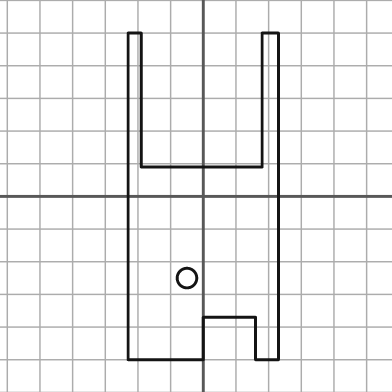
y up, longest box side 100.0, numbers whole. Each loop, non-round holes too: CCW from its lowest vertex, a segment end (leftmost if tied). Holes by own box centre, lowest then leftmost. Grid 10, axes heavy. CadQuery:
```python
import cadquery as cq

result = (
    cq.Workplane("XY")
    .moveTo(-23.0, -50.0)
    .lineTo(0.0, -50.0)
    .lineTo(0.0, -37.0)
    .lineTo(16.0, -37.0)
    .lineTo(16.0, -50.0)
    .lineTo(23.0, -50.0)
    .lineTo(23.0, 50.0)
    .lineTo(18.0, 50.0)
    .lineTo(18.0, 9.0)
    .lineTo(-19.0, 9.0)
    .lineTo(-19.0, 50.0)
    .lineTo(-23.0, 50.0)
    .close()
    .moveTo(-5.0, -25.0)
    .circle(3.0)
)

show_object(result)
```